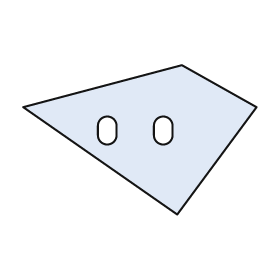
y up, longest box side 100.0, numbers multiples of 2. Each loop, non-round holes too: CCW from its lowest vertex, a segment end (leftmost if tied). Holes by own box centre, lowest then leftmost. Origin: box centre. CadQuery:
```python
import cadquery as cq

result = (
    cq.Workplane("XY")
    .moveTo(16.0, -32.0)
    .lineTo(50.0, 14.0)
    .lineTo(18.0, 32.0)
    .lineTo(-50.0, 14.0)
    .close()
    .moveTo(-18.0, 2.0)
    .threePointArc((-14.0, -2.0), (-10.0, 2.0))
    .lineTo(-10.0, 6.0)
    .threePointArc((-14.0, 10.0), (-18.0, 6.0))
    .close()
    .moveTo(6.0, 2.0)
    .threePointArc((10.0, -2.0), (14.0, 2.0))
    .lineTo(14.0, 6.0)
    .threePointArc((10.0, 10.0), (6.0, 6.0))
    .close()
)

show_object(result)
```